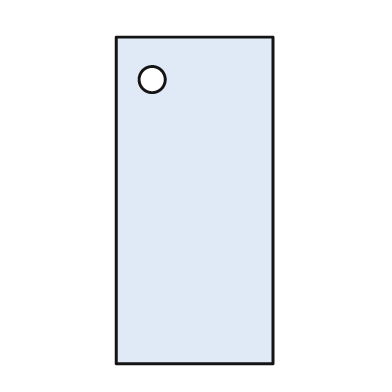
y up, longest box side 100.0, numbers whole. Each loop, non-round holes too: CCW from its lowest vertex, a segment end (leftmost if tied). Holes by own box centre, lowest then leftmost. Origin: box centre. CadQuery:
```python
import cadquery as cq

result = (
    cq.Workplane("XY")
    .moveTo(-24.0, -50.0)
    .lineTo(24.0, -50.0)
    .lineTo(24.0, 50.0)
    .lineTo(-24.0, 50.0)
    .close()
    .moveTo(-13.0, 37.0)
    .circle(4.0)
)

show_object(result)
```